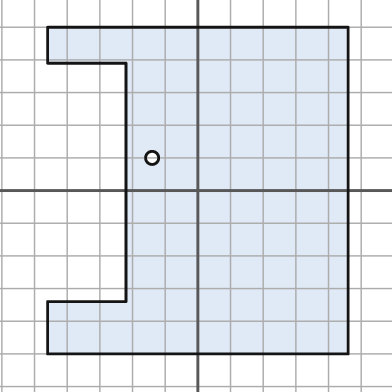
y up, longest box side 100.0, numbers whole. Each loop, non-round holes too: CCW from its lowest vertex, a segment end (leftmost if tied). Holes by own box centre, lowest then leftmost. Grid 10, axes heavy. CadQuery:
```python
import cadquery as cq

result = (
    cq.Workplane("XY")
    .moveTo(-46.0, -50.0)
    .lineTo(46.0, -50.0)
    .lineTo(46.0, 50.0)
    .lineTo(-46.0, 50.0)
    .lineTo(-46.0, 39.0)
    .lineTo(-22.0, 39.0)
    .lineTo(-22.0, -34.0)
    .lineTo(-46.0, -34.0)
    .close()
    .moveTo(-14.0, 10.0)
    .circle(2.0)
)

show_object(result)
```